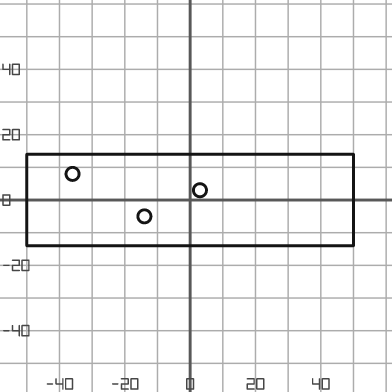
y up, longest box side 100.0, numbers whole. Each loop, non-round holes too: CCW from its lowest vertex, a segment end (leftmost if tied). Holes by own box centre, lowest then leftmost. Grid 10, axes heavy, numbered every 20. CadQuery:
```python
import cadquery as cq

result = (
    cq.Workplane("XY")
    .moveTo(-50.0, -14.0)
    .lineTo(50.0, -14.0)
    .lineTo(50.0, 14.0)
    .lineTo(-50.0, 14.0)
    .close()
    .moveTo(-14.0, -5.0)
    .circle(2.0)
    .moveTo(3.0, 3.0)
    .circle(2.0)
    .moveTo(-36.0, 8.0)
    .circle(2.0)
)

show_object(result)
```